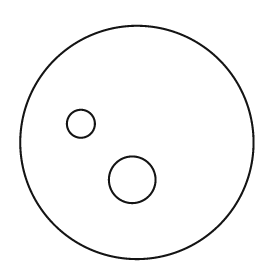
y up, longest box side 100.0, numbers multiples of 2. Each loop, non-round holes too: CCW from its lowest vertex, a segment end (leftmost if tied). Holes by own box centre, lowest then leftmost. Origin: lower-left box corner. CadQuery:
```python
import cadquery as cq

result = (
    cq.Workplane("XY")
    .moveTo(50.0, 50.0)
    .circle(50.0)
    .moveTo(48.0, 34.0)
    .circle(10.0)
    .moveTo(26.0, 58.0)
    .circle(6.0)
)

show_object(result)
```